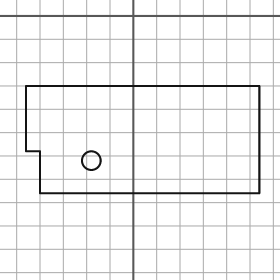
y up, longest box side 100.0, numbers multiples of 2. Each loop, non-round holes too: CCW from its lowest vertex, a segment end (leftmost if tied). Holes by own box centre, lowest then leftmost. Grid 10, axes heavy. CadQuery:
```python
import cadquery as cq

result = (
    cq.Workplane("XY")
    .moveTo(-40.0, -76.0)
    .lineTo(54.0, -76.0)
    .lineTo(54.0, -30.0)
    .lineTo(-46.0, -30.0)
    .lineTo(-46.0, -58.0)
    .lineTo(-40.0, -58.0)
    .close()
    .moveTo(-18.0, -62.0)
    .circle(4.0)
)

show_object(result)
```